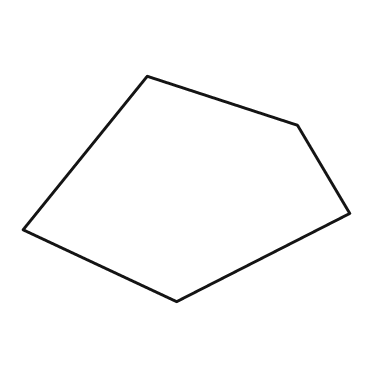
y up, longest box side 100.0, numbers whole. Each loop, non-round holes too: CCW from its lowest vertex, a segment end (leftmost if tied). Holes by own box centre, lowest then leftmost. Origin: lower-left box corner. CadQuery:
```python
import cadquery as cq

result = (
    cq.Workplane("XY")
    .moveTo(47.0, 0.0)
    .lineTo(100.0, 27.0)
    .lineTo(84.0, 54.0)
    .lineTo(38.0, 69.0)
    .lineTo(0.0, 22.0)
    .close()
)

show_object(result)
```